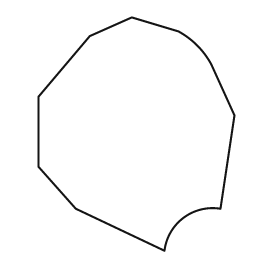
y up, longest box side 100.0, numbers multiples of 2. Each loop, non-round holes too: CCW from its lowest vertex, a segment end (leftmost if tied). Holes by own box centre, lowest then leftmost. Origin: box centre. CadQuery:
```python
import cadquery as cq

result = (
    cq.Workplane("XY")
    .moveTo(12.0, -50.0)
    .threePointArc((20.0, -36.0), (36.0, -32.0))
    .lineTo(42.0, 8.0)
    .lineTo(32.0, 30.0)
    .threePointArc((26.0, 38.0), (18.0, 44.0))
    .lineTo(-2.0, 50.0)
    .lineTo(-20.0, 42.0)
    .lineTo(-42.0, 16.0)
    .lineTo(-42.0, -14.0)
    .lineTo(-26.0, -32.0)
    .close()
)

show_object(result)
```